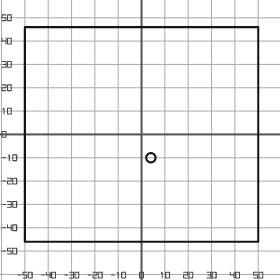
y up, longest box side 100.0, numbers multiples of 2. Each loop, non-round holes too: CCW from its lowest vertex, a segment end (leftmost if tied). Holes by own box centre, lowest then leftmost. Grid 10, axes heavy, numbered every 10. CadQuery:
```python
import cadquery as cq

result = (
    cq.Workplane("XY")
    .moveTo(-50.0, -46.0)
    .lineTo(50.0, -46.0)
    .lineTo(50.0, 46.0)
    .lineTo(-50.0, 46.0)
    .close()
    .moveTo(4.0, -10.0)
    .circle(2.0)
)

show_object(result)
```